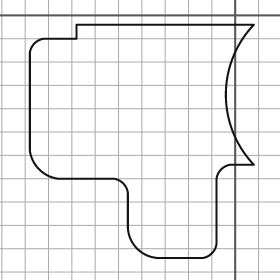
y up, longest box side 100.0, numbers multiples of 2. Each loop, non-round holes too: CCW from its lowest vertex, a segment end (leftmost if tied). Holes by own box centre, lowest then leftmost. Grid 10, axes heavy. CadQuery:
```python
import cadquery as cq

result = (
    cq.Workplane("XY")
    .moveTo(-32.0, -104.0)
    .lineTo(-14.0, -104.0)
    .threePointArc((-10.0, -102.0), (-8.0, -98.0))
    .lineTo(-8.0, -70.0)
    .threePointArc((-6.0, -66.0), (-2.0, -64.0))
    .lineTo(8.0, -64.0)
    .threePointArc((-4.0, -34.0), (8.0, -4.0))
    .lineTo(-68.0, -4.0)
    .lineTo(-68.0, -10.0)
    .lineTo(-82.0, -10.0)
    .threePointArc((-86.0, -12.0), (-88.0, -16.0))
    .lineTo(-88.0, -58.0)
    .threePointArc((-84.0, -66.0), (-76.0, -70.0))
    .lineTo(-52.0, -70.0)
    .threePointArc((-48.0, -72.0), (-46.0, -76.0))
    .lineTo(-46.0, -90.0)
    .threePointArc((-42.0, -100.0), (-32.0, -104.0))
    .close()
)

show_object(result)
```